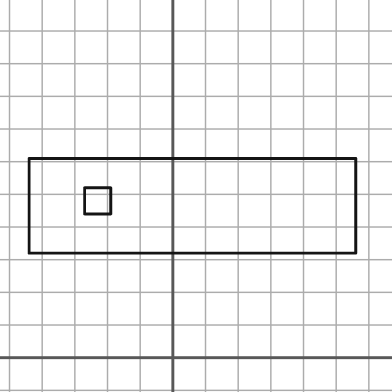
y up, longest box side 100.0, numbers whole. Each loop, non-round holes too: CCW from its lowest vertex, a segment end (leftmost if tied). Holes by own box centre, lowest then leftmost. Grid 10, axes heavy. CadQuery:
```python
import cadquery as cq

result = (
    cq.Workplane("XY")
    .moveTo(-44.0, 32.0)
    .lineTo(56.0, 32.0)
    .lineTo(56.0, 61.0)
    .lineTo(-44.0, 61.0)
    .close()
    .moveTo(-27.0, 44.0)
    .lineTo(-19.0, 44.0)
    .lineTo(-19.0, 52.0)
    .lineTo(-27.0, 52.0)
    .close()
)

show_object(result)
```